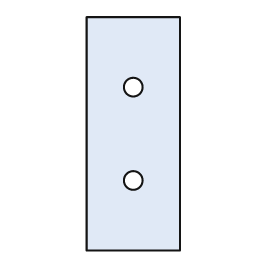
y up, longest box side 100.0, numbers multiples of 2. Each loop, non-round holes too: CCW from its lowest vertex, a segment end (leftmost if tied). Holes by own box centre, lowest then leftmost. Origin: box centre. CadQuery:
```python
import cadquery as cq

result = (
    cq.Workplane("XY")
    .moveTo(-20.0, -50.0)
    .lineTo(20.0, -50.0)
    .lineTo(20.0, 50.0)
    .lineTo(-20.0, 50.0)
    .close()
    .moveTo(0.0, -20.0)
    .circle(4.0)
    .moveTo(0.0, 20.0)
    .circle(4.0)
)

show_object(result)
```